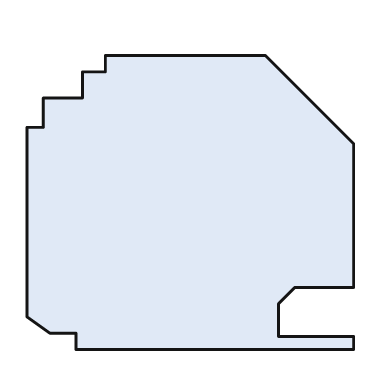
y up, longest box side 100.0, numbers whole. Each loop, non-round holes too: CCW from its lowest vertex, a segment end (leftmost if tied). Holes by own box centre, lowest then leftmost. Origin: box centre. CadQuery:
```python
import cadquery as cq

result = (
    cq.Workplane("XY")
    .moveTo(-35.0, -45.0)
    .lineTo(50.0, -45.0)
    .lineTo(50.0, -41.0)
    .lineTo(27.0, -41.0)
    .lineTo(27.0, -31.0)
    .lineTo(32.0, -26.0)
    .lineTo(50.0, -26.0)
    .lineTo(50.0, 18.0)
    .lineTo(23.0, 45.0)
    .lineTo(-26.0, 45.0)
    .lineTo(-26.0, 40.0)
    .lineTo(-33.0, 40.0)
    .lineTo(-33.0, 32.0)
    .lineTo(-45.0, 32.0)
    .lineTo(-45.0, 23.0)
    .lineTo(-50.0, 23.0)
    .lineTo(-50.0, -35.0)
    .lineTo(-43.0, -40.0)
    .lineTo(-35.0, -40.0)
    .close()
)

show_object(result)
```